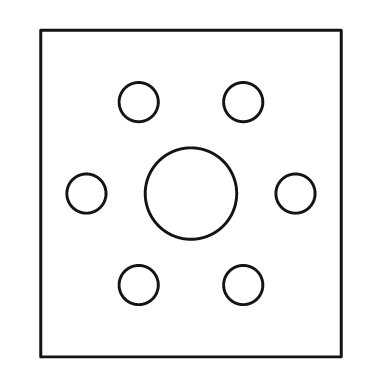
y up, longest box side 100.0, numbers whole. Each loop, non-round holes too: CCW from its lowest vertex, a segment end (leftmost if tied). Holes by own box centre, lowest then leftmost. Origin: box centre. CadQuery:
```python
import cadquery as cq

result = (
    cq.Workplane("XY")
    .moveTo(-46.0, -50.0)
    .lineTo(46.0, -50.0)
    .lineTo(46.0, 50.0)
    .lineTo(-46.0, 50.0)
    .close()
    .moveTo(-16.0, -28.0)
    .circle(6.0)
    .moveTo(16.0, -28.0)
    .circle(6.0)
    .moveTo(-32.0, 0.0)
    .circle(6.0)
    .moveTo(0.0, 0.0)
    .circle(14.0)
    .moveTo(32.0, 0.0)
    .circle(6.0)
    .moveTo(-16.0, 28.0)
    .circle(6.0)
    .moveTo(16.0, 28.0)
    .circle(6.0)
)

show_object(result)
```